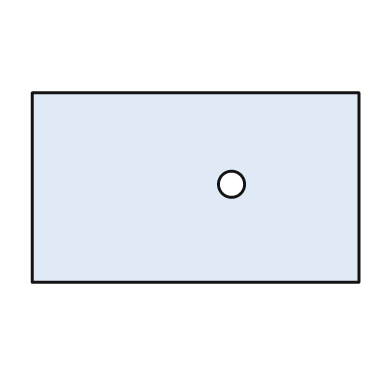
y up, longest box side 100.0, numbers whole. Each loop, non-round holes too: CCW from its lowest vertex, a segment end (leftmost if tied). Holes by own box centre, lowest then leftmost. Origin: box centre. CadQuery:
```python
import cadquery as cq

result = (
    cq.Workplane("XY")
    .moveTo(-50.0, -29.0)
    .lineTo(50.0, -29.0)
    .lineTo(50.0, 29.0)
    .lineTo(-50.0, 29.0)
    .close()
    .moveTo(11.0, 1.0)
    .circle(4.0)
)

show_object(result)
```